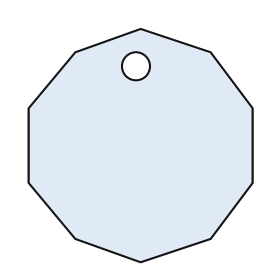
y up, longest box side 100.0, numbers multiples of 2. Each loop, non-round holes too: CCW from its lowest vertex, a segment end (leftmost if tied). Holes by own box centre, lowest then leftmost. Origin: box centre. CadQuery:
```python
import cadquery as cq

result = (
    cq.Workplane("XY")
    .moveTo(0.0, -50.0)
    .lineTo(30.0, -40.0)
    .lineTo(48.0, -16.0)
    .lineTo(48.0, 16.0)
    .lineTo(30.0, 40.0)
    .lineTo(0.0, 50.0)
    .lineTo(-28.0, 40.0)
    .lineTo(-48.0, 16.0)
    .lineTo(-48.0, -16.0)
    .lineTo(-28.0, -40.0)
    .close()
    .moveTo(-2.0, 34.0)
    .circle(6.0)
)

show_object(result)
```